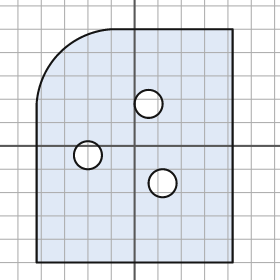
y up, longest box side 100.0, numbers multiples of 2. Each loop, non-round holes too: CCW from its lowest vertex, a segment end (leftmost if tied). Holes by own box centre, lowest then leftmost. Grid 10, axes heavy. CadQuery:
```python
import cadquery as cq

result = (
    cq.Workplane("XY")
    .moveTo(-42.0, -50.0)
    .lineTo(42.0, -50.0)
    .lineTo(42.0, 50.0)
    .lineTo(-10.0, 50.0)
    .threePointArc((-32.0, 40.0), (-42.0, 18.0))
    .close()
    .moveTo(12.0, -16.0)
    .circle(6.0)
    .moveTo(-20.0, -4.0)
    .circle(6.0)
    .moveTo(6.0, 18.0)
    .circle(6.0)
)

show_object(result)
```